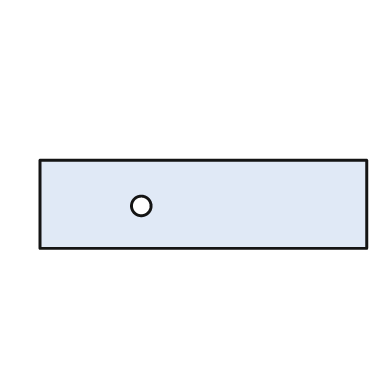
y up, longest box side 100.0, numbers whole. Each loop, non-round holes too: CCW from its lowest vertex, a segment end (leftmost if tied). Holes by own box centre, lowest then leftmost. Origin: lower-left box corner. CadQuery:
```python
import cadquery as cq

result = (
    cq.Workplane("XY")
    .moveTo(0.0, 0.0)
    .lineTo(100.0, 0.0)
    .lineTo(100.0, 27.0)
    .lineTo(0.0, 27.0)
    .close()
    .moveTo(31.0, 13.0)
    .circle(3.0)
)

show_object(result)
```